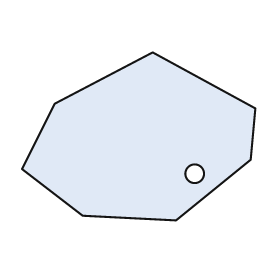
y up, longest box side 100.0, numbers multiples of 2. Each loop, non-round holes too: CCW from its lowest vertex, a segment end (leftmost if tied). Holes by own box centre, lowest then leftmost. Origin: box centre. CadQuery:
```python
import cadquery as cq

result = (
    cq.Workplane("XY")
    .moveTo(16.0, -36.0)
    .lineTo(48.0, -10.0)
    .lineTo(50.0, 12.0)
    .lineTo(6.0, 36.0)
    .lineTo(-36.0, 14.0)
    .lineTo(-50.0, -14.0)
    .lineTo(-24.0, -34.0)
    .close()
    .moveTo(24.0, -16.0)
    .circle(4.0)
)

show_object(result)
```